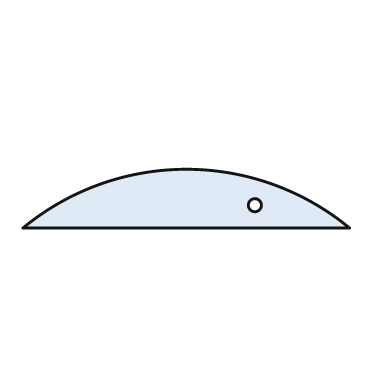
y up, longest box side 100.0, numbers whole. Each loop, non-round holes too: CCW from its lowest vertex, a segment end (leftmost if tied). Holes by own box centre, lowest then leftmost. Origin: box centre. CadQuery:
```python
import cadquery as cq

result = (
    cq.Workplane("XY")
    .moveTo(-50.0, -9.0)
    .lineTo(50.0, -9.0)
    .threePointArc((0.0, 9.0), (-50.0, -9.0))
    .close()
    .moveTo(21.0, -2.0)
    .circle(2.0)
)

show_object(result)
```